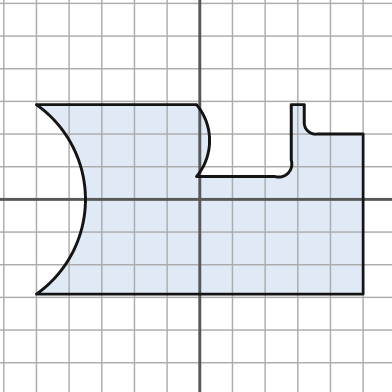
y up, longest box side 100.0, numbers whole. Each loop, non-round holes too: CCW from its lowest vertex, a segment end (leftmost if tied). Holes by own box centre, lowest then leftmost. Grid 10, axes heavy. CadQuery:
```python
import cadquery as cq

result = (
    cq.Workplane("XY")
    .moveTo(-50.0, -29.0)
    .lineTo(50.0, -29.0)
    .lineTo(50.0, 20.0)
    .lineTo(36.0, 20.0)
    .threePointArc((33.0, 21.0), (32.0, 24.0))
    .lineTo(32.0, 29.0)
    .lineTo(28.0, 29.0)
    .lineTo(28.0, 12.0)
    .threePointArc((27.0, 8.0), (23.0, 7.0))
    .lineTo(-1.0, 7.0)
    .threePointArc((3.0, 18.0), (-1.0, 29.0))
    .lineTo(-50.0, 29.0)
    .threePointArc((-35.0, 0.0), (-50.0, -29.0))
    .close()
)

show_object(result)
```